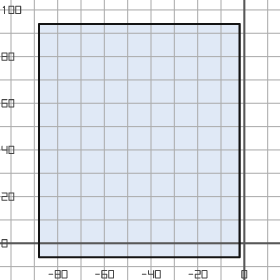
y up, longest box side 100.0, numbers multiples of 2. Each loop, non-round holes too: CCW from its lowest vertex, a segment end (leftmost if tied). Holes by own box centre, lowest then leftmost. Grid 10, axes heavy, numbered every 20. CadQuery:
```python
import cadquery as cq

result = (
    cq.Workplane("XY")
    .moveTo(-88.0, -6.0)
    .lineTo(-2.0, -6.0)
    .lineTo(-2.0, 94.0)
    .lineTo(-88.0, 94.0)
    .close()
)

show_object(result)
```